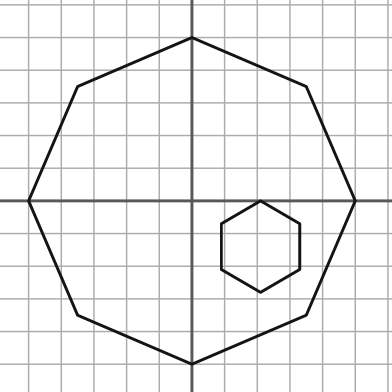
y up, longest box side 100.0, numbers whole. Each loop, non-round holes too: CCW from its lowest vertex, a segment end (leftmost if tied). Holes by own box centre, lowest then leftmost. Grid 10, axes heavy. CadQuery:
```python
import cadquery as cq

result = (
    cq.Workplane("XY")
    .moveTo(0.0, -50.0)
    .lineTo(35.0, -35.0)
    .lineTo(50.0, 0.0)
    .lineTo(35.0, 35.0)
    .lineTo(0.0, 50.0)
    .lineTo(-35.0, 35.0)
    .lineTo(-50.0, 0.0)
    .lineTo(-35.0, -35.0)
    .close()
    .moveTo(21.0, -28.0)
    .lineTo(33.0, -21.0)
    .lineTo(33.0, -7.0)
    .lineTo(21.0, 0.0)
    .lineTo(9.0, -7.0)
    .lineTo(9.0, -21.0)
    .close()
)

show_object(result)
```